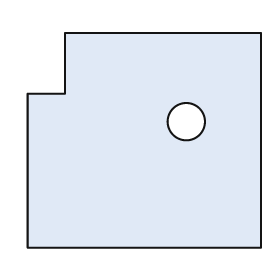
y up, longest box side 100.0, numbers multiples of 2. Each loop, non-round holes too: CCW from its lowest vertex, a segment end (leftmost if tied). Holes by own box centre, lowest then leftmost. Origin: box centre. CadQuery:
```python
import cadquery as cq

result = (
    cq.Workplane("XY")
    .moveTo(-50.0, -46.0)
    .lineTo(50.0, -46.0)
    .lineTo(50.0, 46.0)
    .lineTo(-34.0, 46.0)
    .lineTo(-34.0, 20.0)
    .lineTo(-50.0, 20.0)
    .close()
    .moveTo(18.0, 8.0)
    .circle(8.0)
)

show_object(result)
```